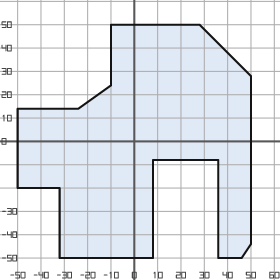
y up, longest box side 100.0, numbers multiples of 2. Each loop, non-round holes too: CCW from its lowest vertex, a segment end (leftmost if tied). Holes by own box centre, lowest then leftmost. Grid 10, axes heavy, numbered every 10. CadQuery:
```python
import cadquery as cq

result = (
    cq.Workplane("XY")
    .moveTo(-32.0, -50.0)
    .lineTo(8.0, -50.0)
    .lineTo(8.0, -8.0)
    .lineTo(36.0, -8.0)
    .lineTo(36.0, -50.0)
    .lineTo(46.0, -50.0)
    .lineTo(50.0, -44.0)
    .lineTo(50.0, 28.0)
    .lineTo(28.0, 50.0)
    .lineTo(-10.0, 50.0)
    .lineTo(-10.0, 24.0)
    .lineTo(-24.0, 14.0)
    .lineTo(-50.0, 14.0)
    .lineTo(-50.0, -20.0)
    .lineTo(-32.0, -20.0)
    .close()
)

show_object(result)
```